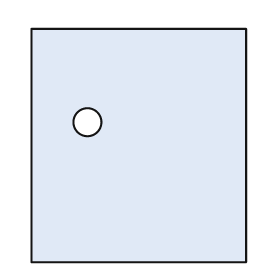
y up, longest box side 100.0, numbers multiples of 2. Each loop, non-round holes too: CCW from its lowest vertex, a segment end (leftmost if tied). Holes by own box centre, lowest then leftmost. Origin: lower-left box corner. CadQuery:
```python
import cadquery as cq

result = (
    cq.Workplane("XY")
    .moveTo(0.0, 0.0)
    .lineTo(92.0, 0.0)
    .lineTo(92.0, 100.0)
    .lineTo(0.0, 100.0)
    .close()
    .moveTo(24.0, 60.0)
    .circle(6.0)
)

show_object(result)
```